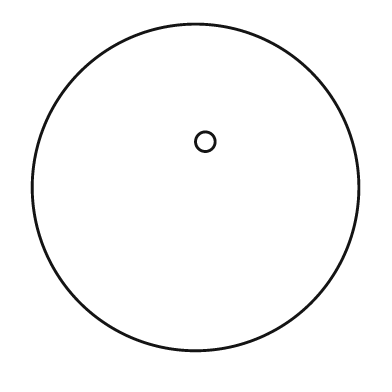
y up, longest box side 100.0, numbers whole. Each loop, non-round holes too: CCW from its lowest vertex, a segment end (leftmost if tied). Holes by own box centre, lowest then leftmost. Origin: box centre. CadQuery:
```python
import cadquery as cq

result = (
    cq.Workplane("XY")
    .moveTo(0.0, 0.0)
    .circle(50.0)
    .moveTo(3.0, 14.0)
    .circle(3.0)
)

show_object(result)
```